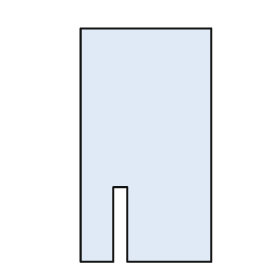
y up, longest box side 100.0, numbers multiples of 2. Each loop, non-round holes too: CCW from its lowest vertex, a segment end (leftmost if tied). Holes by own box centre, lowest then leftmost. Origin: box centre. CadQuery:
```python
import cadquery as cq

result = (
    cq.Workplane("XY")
    .moveTo(-28.0, -50.0)
    .lineTo(-14.0, -50.0)
    .lineTo(-14.0, -18.0)
    .lineTo(-8.0, -18.0)
    .lineTo(-8.0, -50.0)
    .lineTo(28.0, -50.0)
    .lineTo(28.0, 50.0)
    .lineTo(-28.0, 50.0)
    .close()
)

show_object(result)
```